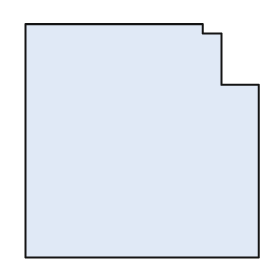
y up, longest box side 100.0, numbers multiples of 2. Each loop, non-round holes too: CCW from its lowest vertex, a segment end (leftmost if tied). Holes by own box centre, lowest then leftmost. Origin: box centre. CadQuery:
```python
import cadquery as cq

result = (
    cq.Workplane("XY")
    .moveTo(-50.0, -50.0)
    .lineTo(50.0, -50.0)
    .lineTo(50.0, 24.0)
    .lineTo(34.0, 24.0)
    .lineTo(34.0, 46.0)
    .lineTo(26.0, 46.0)
    .lineTo(26.0, 50.0)
    .lineTo(-50.0, 50.0)
    .close()
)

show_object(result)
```